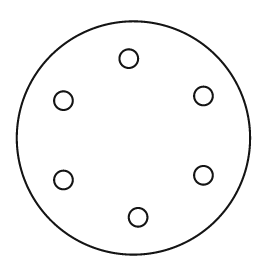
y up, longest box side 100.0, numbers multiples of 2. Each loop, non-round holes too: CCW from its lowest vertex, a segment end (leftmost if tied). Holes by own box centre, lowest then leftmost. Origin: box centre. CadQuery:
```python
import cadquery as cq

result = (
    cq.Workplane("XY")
    .moveTo(0.0, 0.0)
    .circle(50.0)
    .moveTo(2.0, -34.0)
    .circle(4.0)
    .moveTo(-30.0, -18.0)
    .circle(4.0)
    .moveTo(30.0, -16.0)
    .circle(4.0)
    .moveTo(-30.0, 16.0)
    .circle(4.0)
    .moveTo(30.0, 18.0)
    .circle(4.0)
    .moveTo(-2.0, 34.0)
    .circle(4.0)
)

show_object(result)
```